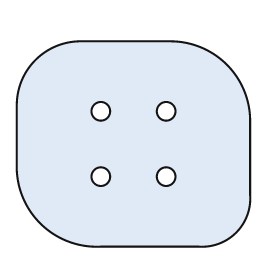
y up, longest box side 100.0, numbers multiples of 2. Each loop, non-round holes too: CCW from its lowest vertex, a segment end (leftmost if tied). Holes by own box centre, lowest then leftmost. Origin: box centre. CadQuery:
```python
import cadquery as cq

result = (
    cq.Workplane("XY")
    .moveTo(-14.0, -44.0)
    .lineTo(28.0, -44.0)
    .threePointArc((44.0, -38.0), (50.0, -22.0))
    .lineTo(50.0, 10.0)
    .threePointArc((40.0, 34.0), (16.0, 44.0))
    .lineTo(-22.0, 44.0)
    .threePointArc((-42.0, 36.0), (-50.0, 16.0))
    .lineTo(-50.0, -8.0)
    .threePointArc((-40.0, -34.0), (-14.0, -44.0))
    .close()
    .moveTo(-14.0, -14.0)
    .circle(4.0)
    .moveTo(14.0, -14.0)
    .circle(4.0)
    .moveTo(-14.0, 14.0)
    .circle(4.0)
    .moveTo(14.0, 14.0)
    .circle(4.0)
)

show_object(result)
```